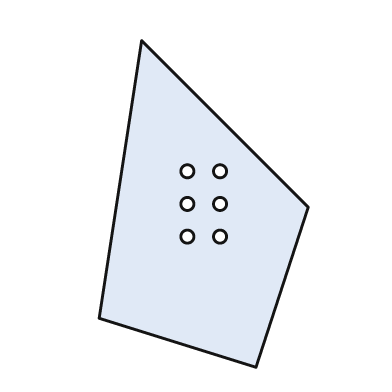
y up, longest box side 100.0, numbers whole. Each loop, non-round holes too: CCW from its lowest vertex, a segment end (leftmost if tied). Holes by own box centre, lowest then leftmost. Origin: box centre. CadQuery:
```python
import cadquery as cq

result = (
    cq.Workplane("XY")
    .moveTo(16.0, -50.0)
    .lineTo(32.0, -1.0)
    .lineTo(-19.0, 50.0)
    .lineTo(-32.0, -35.0)
    .close()
    .moveTo(-5.0, -10.0)
    .circle(2.0)
    .moveTo(5.0, -10.0)
    .circle(2.0)
    .moveTo(-5.0, 0.0)
    .circle(2.0)
    .moveTo(5.0, 0.0)
    .circle(2.0)
    .moveTo(-5.0, 10.0)
    .circle(2.0)
    .moveTo(5.0, 10.0)
    .circle(2.0)
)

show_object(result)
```